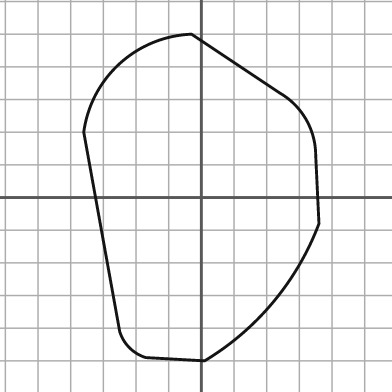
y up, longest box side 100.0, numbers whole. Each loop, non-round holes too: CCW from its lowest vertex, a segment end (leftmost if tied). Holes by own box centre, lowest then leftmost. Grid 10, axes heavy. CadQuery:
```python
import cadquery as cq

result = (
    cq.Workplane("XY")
    .moveTo(1.0, -50.0)
    .threePointArc((22.0, -32.0), (36.0, -8.0))
    .lineTo(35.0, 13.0)
    .threePointArc((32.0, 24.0), (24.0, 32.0))
    .lineTo(-3.0, 50.0)
    .threePointArc((-25.0, 41.0), (-36.0, 20.0))
    .lineTo(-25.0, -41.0)
    .threePointArc((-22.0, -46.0), (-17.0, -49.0))
    .close()
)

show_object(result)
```